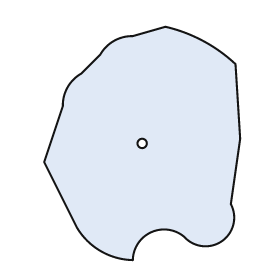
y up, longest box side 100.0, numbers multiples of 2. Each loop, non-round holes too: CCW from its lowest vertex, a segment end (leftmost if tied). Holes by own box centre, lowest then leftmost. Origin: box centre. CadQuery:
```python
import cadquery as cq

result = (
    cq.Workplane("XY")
    .moveTo(-4.0, -50.0)
    .threePointArc((4.0, -38.0), (18.0, -40.0))
    .threePointArc((34.0, -42.0), (38.0, -26.0))
    .lineTo(42.0, 2.0)
    .lineTo(40.0, 34.0)
    .threePointArc((26.0, 44.0), (10.0, 50.0))
    .lineTo(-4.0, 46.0)
    .threePointArc((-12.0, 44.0), (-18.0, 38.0))
    .lineTo(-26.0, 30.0)
    .threePointArc((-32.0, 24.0), (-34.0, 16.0))
    .lineTo(-42.0, -8.0)
    .lineTo(-28.0, -36.0)
    .threePointArc((-18.0, -46.0), (-4.0, -50.0))
    .close()
    .moveTo(0.0, 0.0)
    .circle(2.0)
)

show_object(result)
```